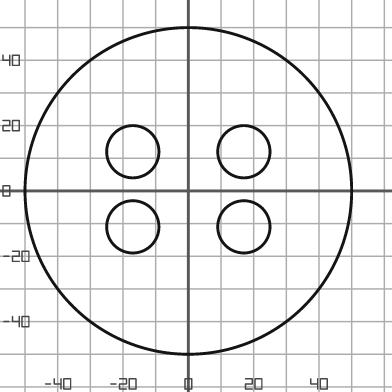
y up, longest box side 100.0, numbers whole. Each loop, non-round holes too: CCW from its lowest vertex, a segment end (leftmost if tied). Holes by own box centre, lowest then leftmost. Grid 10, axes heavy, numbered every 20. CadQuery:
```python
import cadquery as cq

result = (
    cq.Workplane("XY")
    .moveTo(0.0, 0.0)
    .circle(50.0)
    .moveTo(-17.0, -11.0)
    .circle(8.0)
    .moveTo(17.0, -11.0)
    .circle(8.0)
    .moveTo(-17.0, 12.0)
    .circle(8.0)
    .moveTo(17.0, 12.0)
    .circle(8.0)
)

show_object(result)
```